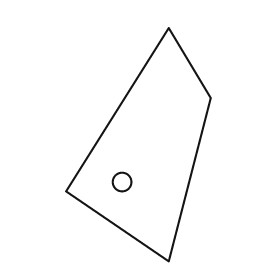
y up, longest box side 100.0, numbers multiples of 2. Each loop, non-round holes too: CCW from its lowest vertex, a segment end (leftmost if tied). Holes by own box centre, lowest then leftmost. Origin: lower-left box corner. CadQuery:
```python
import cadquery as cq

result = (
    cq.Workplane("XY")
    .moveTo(44.0, 0.0)
    .lineTo(62.0, 70.0)
    .lineTo(44.0, 100.0)
    .lineTo(0.0, 30.0)
    .close()
    .moveTo(24.0, 34.0)
    .circle(4.0)
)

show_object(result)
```